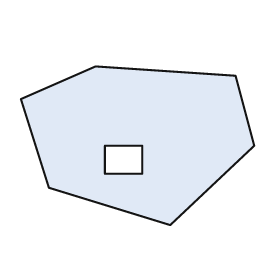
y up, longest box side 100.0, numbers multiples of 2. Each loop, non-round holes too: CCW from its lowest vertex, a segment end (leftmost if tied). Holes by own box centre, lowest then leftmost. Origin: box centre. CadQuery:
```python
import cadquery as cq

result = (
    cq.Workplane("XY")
    .moveTo(14.0, -34.0)
    .lineTo(50.0, 0.0)
    .lineTo(42.0, 30.0)
    .lineTo(-18.0, 34.0)
    .lineTo(-50.0, 20.0)
    .lineTo(-38.0, -18.0)
    .close()
    .moveTo(-14.0, -12.0)
    .lineTo(2.0, -12.0)
    .lineTo(2.0, 0.0)
    .lineTo(-14.0, 0.0)
    .close()
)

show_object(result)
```